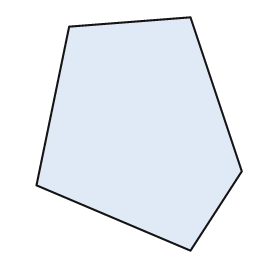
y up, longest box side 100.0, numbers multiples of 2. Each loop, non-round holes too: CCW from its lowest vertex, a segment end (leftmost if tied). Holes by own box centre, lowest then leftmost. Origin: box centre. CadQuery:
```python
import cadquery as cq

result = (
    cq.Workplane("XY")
    .moveTo(22.0, -50.0)
    .lineTo(44.0, -16.0)
    .lineTo(22.0, 50.0)
    .lineTo(-30.0, 46.0)
    .lineTo(-44.0, -22.0)
    .close()
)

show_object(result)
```